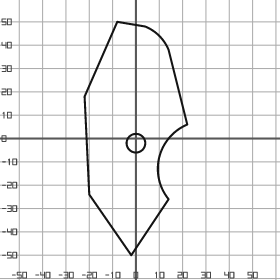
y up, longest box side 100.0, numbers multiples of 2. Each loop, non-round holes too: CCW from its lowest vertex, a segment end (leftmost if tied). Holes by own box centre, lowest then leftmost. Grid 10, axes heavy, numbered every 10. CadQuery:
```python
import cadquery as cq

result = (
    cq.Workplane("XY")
    .moveTo(-2.0, -50.0)
    .lineTo(14.0, -26.0)
    .threePointArc((10.0, -8.0), (22.0, 6.0))
    .lineTo(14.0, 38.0)
    .threePointArc((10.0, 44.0), (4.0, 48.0))
    .lineTo(-8.0, 50.0)
    .lineTo(-22.0, 18.0)
    .lineTo(-20.0, -24.0)
    .close()
    .moveTo(0.0, -2.0)
    .circle(4.0)
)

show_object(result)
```